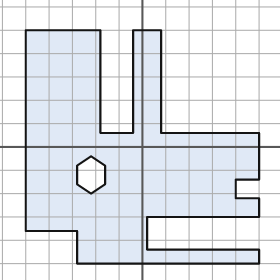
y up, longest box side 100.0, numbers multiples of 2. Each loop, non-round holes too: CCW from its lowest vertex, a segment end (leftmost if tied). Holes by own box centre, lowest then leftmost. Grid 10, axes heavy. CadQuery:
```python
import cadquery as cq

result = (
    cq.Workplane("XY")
    .moveTo(-28.0, -50.0)
    .lineTo(50.0, -50.0)
    .lineTo(50.0, -44.0)
    .lineTo(2.0, -44.0)
    .lineTo(2.0, -30.0)
    .lineTo(50.0, -30.0)
    .lineTo(50.0, -22.0)
    .lineTo(40.0, -22.0)
    .lineTo(40.0, -14.0)
    .lineTo(50.0, -14.0)
    .lineTo(50.0, 6.0)
    .lineTo(8.0, 6.0)
    .lineTo(8.0, 50.0)
    .lineTo(-4.0, 50.0)
    .lineTo(-4.0, 6.0)
    .lineTo(-18.0, 6.0)
    .lineTo(-18.0, 50.0)
    .lineTo(-50.0, 50.0)
    .lineTo(-50.0, -36.0)
    .lineTo(-28.0, -36.0)
    .close()
    .moveTo(-22.0, -20.0)
    .lineTo(-16.0, -16.0)
    .lineTo(-16.0, -8.0)
    .lineTo(-22.0, -4.0)
    .lineTo(-28.0, -8.0)
    .lineTo(-28.0, -16.0)
    .close()
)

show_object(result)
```